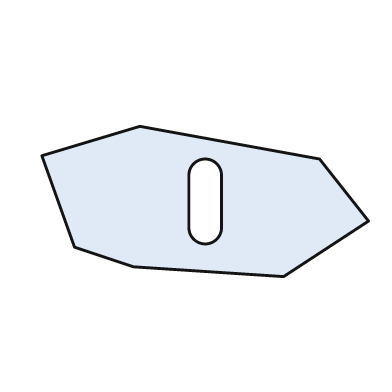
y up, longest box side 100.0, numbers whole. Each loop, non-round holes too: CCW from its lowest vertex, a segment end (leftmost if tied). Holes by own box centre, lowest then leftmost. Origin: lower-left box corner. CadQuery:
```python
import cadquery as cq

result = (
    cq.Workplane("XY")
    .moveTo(74.0, 0.0)
    .lineTo(100.0, 17.0)
    .lineTo(85.0, 36.0)
    .lineTo(30.0, 46.0)
    .lineTo(0.0, 37.0)
    .lineTo(10.0, 9.0)
    .lineTo(28.0, 3.0)
    .close()
    .moveTo(45.0, 15.0)
    .threePointArc((50.0, 10.0), (55.0, 15.0))
    .lineTo(55.0, 31.0)
    .threePointArc((50.0, 36.0), (45.0, 31.0))
    .close()
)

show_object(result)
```